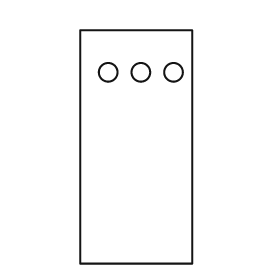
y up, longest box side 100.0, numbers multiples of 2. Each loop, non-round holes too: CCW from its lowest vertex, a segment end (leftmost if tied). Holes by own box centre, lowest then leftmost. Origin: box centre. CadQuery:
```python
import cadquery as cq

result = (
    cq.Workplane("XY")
    .moveTo(-24.0, -50.0)
    .lineTo(24.0, -50.0)
    .lineTo(24.0, 50.0)
    .lineTo(-24.0, 50.0)
    .close()
    .moveTo(-12.0, 32.0)
    .circle(4.0)
    .moveTo(2.0, 32.0)
    .circle(4.0)
    .moveTo(16.0, 32.0)
    .circle(4.0)
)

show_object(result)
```